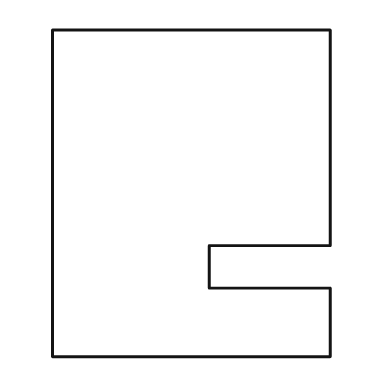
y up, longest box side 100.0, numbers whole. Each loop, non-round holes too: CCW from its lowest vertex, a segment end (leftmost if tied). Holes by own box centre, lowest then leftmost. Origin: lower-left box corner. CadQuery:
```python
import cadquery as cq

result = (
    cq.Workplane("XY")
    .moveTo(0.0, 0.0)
    .lineTo(85.0, 0.0)
    .lineTo(85.0, 21.0)
    .lineTo(48.0, 21.0)
    .lineTo(48.0, 34.0)
    .lineTo(85.0, 34.0)
    .lineTo(85.0, 100.0)
    .lineTo(0.0, 100.0)
    .close()
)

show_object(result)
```